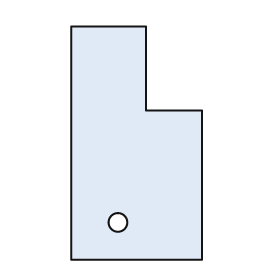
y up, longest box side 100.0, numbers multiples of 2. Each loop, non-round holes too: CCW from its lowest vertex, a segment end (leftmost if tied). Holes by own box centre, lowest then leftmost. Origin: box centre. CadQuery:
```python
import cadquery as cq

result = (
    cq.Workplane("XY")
    .moveTo(-28.0, -50.0)
    .lineTo(28.0, -50.0)
    .lineTo(28.0, 14.0)
    .lineTo(4.0, 14.0)
    .lineTo(4.0, 50.0)
    .lineTo(-28.0, 50.0)
    .close()
    .moveTo(-8.0, -34.0)
    .circle(4.0)
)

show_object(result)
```